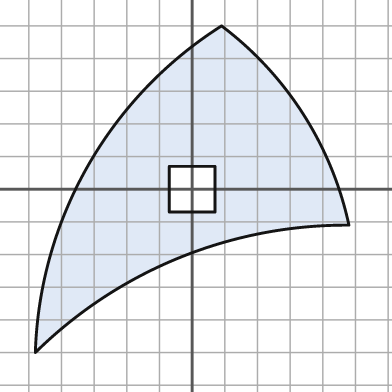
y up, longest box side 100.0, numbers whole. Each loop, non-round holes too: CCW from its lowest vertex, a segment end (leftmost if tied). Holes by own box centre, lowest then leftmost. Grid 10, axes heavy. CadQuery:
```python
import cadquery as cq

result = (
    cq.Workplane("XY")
    .moveTo(-48.0, -50.0)
    .threePointArc((-4.0, -21.0), (48.0, -11.0))
    .threePointArc((34.0, 23.0), (9.0, 50.0))
    .threePointArc((-32.0, 7.0), (-48.0, -50.0))
    .close()
    .moveTo(-7.0, -7.0)
    .lineTo(7.0, -7.0)
    .lineTo(7.0, 7.0)
    .lineTo(-7.0, 7.0)
    .close()
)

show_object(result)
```